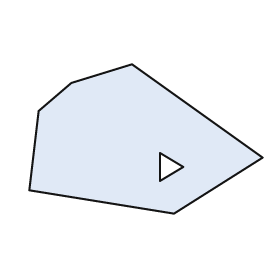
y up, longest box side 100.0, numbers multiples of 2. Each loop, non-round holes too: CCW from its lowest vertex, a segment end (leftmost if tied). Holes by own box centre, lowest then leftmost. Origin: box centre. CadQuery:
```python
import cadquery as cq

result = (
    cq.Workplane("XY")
    .moveTo(12.0, -32.0)
    .lineTo(50.0, -8.0)
    .lineTo(-6.0, 32.0)
    .lineTo(-32.0, 24.0)
    .lineTo(-46.0, 12.0)
    .lineTo(-50.0, -22.0)
    .close()
    .moveTo(6.0, -18.0)
    .lineTo(16.0, -12.0)
    .lineTo(6.0, -6.0)
    .close()
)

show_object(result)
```